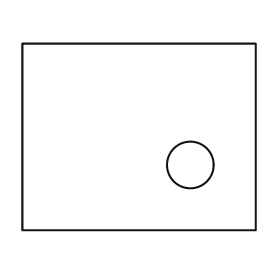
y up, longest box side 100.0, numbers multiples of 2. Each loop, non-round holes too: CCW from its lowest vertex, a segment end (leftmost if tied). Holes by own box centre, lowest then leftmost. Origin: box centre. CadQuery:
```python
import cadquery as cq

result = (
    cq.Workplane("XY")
    .moveTo(-50.0, -40.0)
    .lineTo(50.0, -40.0)
    .lineTo(50.0, 40.0)
    .lineTo(-50.0, 40.0)
    .close()
    .moveTo(22.0, -12.0)
    .circle(10.0)
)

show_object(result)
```